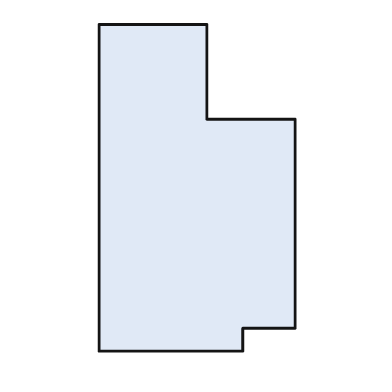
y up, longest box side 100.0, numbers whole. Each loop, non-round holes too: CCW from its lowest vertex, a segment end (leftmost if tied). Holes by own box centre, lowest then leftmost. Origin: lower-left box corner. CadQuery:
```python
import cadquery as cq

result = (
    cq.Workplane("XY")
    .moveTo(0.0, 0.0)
    .lineTo(44.0, 0.0)
    .lineTo(44.0, 7.0)
    .lineTo(60.0, 7.0)
    .lineTo(60.0, 71.0)
    .lineTo(33.0, 71.0)
    .lineTo(33.0, 100.0)
    .lineTo(0.0, 100.0)
    .close()
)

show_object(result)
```